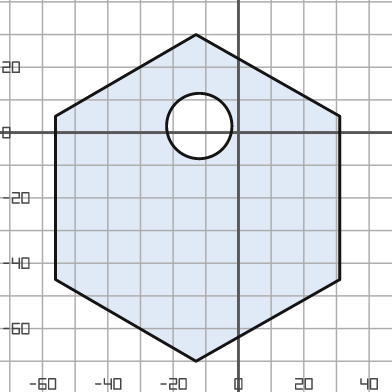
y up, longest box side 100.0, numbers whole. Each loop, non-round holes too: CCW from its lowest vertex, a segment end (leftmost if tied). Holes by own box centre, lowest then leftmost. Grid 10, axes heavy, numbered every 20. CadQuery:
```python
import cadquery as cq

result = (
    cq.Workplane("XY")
    .moveTo(-13.0, -70.0)
    .lineTo(31.0, -45.0)
    .lineTo(31.0, 5.0)
    .lineTo(-13.0, 30.0)
    .lineTo(-56.0, 5.0)
    .lineTo(-56.0, -45.0)
    .close()
    .moveTo(-12.0, 2.0)
    .circle(10.0)
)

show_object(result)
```